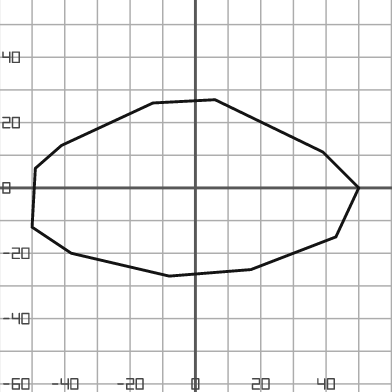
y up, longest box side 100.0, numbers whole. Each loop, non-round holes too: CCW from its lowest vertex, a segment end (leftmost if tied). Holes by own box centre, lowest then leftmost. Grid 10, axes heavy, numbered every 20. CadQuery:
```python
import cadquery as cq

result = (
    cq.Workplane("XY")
    .moveTo(-8.0, -27.0)
    .lineTo(17.0, -25.0)
    .lineTo(43.0, -15.0)
    .lineTo(50.0, 0.0)
    .lineTo(39.0, 11.0)
    .lineTo(6.0, 27.0)
    .lineTo(-13.0, 26.0)
    .lineTo(-41.0, 13.0)
    .lineTo(-49.0, 6.0)
    .lineTo(-50.0, -12.0)
    .lineTo(-38.0, -20.0)
    .close()
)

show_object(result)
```